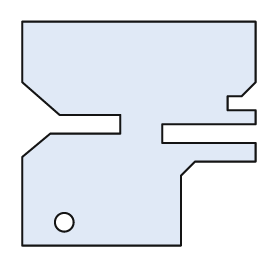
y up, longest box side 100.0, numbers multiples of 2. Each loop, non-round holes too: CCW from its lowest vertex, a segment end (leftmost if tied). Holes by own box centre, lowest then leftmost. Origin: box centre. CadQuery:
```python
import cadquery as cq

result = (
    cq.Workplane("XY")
    .moveTo(-50.0, -48.0)
    .lineTo(18.0, -48.0)
    .lineTo(18.0, -18.0)
    .lineTo(24.0, -12.0)
    .lineTo(50.0, -12.0)
    .lineTo(50.0, -4.0)
    .lineTo(10.0, -4.0)
    .lineTo(10.0, 4.0)
    .lineTo(50.0, 4.0)
    .lineTo(50.0, 10.0)
    .lineTo(38.0, 10.0)
    .lineTo(38.0, 16.0)
    .lineTo(44.0, 16.0)
    .lineTo(50.0, 22.0)
    .lineTo(50.0, 48.0)
    .lineTo(-50.0, 48.0)
    .lineTo(-50.0, 22.0)
    .lineTo(-34.0, 8.0)
    .lineTo(-8.0, 8.0)
    .lineTo(-8.0, 0.0)
    .lineTo(-38.0, 0.0)
    .lineTo(-50.0, -10.0)
    .close()
    .moveTo(-32.0, -38.0)
    .circle(4.0)
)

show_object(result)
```